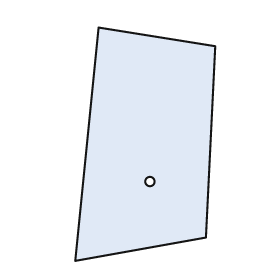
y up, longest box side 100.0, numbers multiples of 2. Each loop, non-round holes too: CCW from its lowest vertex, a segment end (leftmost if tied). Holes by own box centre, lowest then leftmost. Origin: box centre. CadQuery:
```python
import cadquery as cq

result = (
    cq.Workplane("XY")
    .moveTo(-30.0, -50.0)
    .lineTo(26.0, -40.0)
    .lineTo(30.0, 42.0)
    .lineTo(-20.0, 50.0)
    .close()
    .moveTo(2.0, -16.0)
    .circle(2.0)
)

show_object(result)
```